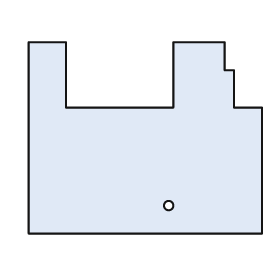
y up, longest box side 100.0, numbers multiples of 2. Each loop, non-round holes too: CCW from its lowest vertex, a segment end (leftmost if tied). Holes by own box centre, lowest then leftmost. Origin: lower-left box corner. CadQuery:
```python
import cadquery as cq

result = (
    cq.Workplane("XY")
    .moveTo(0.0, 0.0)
    .lineTo(100.0, 0.0)
    .lineTo(100.0, 54.0)
    .lineTo(88.0, 54.0)
    .lineTo(88.0, 70.0)
    .lineTo(84.0, 70.0)
    .lineTo(84.0, 82.0)
    .lineTo(62.0, 82.0)
    .lineTo(62.0, 54.0)
    .lineTo(16.0, 54.0)
    .lineTo(16.0, 82.0)
    .lineTo(0.0, 82.0)
    .close()
    .moveTo(60.0, 12.0)
    .circle(2.0)
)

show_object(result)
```